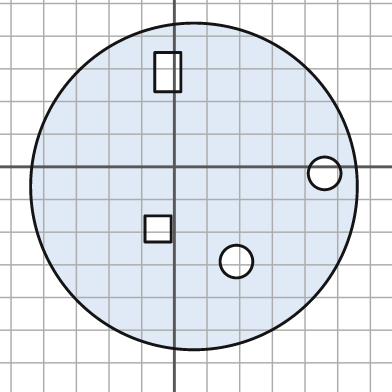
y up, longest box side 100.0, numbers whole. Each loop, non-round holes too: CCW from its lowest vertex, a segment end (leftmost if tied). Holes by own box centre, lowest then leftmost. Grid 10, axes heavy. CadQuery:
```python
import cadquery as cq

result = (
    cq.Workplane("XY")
    .moveTo(6.0, -6.0)
    .circle(50.0)
    .moveTo(19.0, -29.0)
    .circle(5.0)
    .moveTo(-9.0, -23.0)
    .lineTo(-1.0, -23.0)
    .lineTo(-1.0, -15.0)
    .lineTo(-9.0, -15.0)
    .close()
    .moveTo(46.0, -2.0)
    .circle(5.0)
    .moveTo(-6.0, 23.0)
    .lineTo(2.0, 23.0)
    .lineTo(2.0, 35.0)
    .lineTo(-6.0, 35.0)
    .close()
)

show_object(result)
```